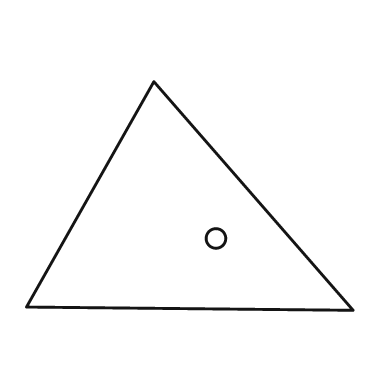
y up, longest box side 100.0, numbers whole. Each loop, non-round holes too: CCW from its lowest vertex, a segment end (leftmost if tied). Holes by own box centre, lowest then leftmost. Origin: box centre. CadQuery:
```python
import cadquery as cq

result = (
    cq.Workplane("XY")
    .moveTo(50.0, -35.0)
    .lineTo(-11.0, 35.0)
    .lineTo(-50.0, -34.0)
    .close()
    .moveTo(8.0, -13.0)
    .circle(3.0)
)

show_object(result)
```